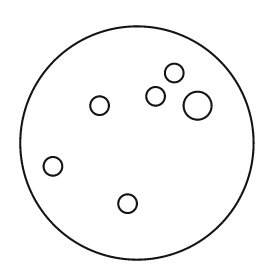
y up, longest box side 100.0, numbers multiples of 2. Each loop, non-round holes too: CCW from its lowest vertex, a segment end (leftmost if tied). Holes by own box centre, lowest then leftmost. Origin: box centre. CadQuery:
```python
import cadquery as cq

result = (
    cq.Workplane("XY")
    .moveTo(0.0, 0.0)
    .circle(50.0)
    .moveTo(-4.0, -26.0)
    .circle(4.0)
    .moveTo(-36.0, -10.0)
    .circle(4.0)
    .moveTo(-16.0, 16.0)
    .circle(4.0)
    .moveTo(26.0, 16.0)
    .circle(6.0)
    .moveTo(8.0, 20.0)
    .circle(4.0)
    .moveTo(16.0, 30.0)
    .circle(4.0)
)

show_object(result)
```